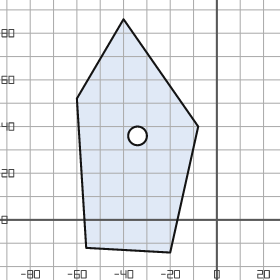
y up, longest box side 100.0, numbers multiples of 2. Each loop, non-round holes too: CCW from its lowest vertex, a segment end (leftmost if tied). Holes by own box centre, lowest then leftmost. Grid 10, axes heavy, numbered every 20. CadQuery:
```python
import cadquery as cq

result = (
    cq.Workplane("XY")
    .moveTo(-20.0, -14.0)
    .lineTo(-8.0, 40.0)
    .lineTo(-40.0, 86.0)
    .lineTo(-60.0, 52.0)
    .lineTo(-56.0, -12.0)
    .close()
    .moveTo(-34.0, 36.0)
    .circle(4.0)
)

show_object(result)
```